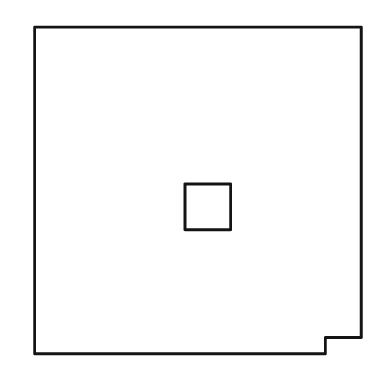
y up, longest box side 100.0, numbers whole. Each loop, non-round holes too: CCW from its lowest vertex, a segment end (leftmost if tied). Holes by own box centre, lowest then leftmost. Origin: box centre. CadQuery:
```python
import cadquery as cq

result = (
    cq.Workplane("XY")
    .moveTo(-50.0, -50.0)
    .lineTo(39.0, -50.0)
    .lineTo(39.0, -45.0)
    .lineTo(50.0, -45.0)
    .lineTo(50.0, 50.0)
    .lineTo(-50.0, 50.0)
    .close()
    .moveTo(-4.0, -12.0)
    .lineTo(10.0, -12.0)
    .lineTo(10.0, 2.0)
    .lineTo(-4.0, 2.0)
    .close()
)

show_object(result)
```